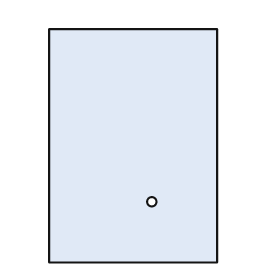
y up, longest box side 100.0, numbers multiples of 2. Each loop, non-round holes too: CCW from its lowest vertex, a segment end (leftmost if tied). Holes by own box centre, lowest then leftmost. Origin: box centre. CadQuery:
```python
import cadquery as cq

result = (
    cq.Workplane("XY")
    .moveTo(-36.0, -50.0)
    .lineTo(36.0, -50.0)
    .lineTo(36.0, 50.0)
    .lineTo(-36.0, 50.0)
    .close()
    .moveTo(8.0, -24.0)
    .circle(2.0)
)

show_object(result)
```